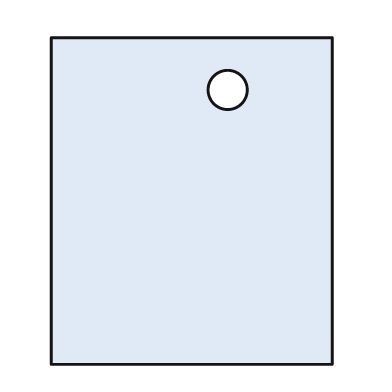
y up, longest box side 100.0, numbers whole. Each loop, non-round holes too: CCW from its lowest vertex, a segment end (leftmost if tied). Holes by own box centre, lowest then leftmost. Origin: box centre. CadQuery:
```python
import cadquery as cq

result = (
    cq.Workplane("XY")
    .moveTo(-43.0, -50.0)
    .lineTo(43.0, -50.0)
    .lineTo(43.0, 50.0)
    .lineTo(-43.0, 50.0)
    .close()
    .moveTo(11.0, 34.0)
    .circle(6.0)
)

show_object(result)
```